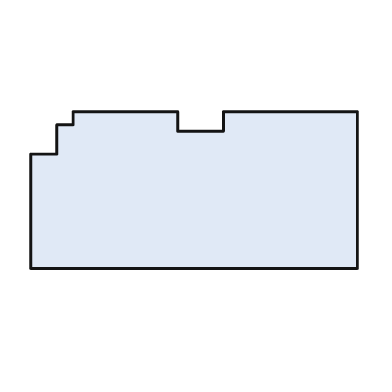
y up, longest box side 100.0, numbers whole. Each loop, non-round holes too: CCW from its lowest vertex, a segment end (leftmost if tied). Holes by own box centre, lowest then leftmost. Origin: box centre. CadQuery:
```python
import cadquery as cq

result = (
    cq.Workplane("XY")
    .moveTo(-50.0, -24.0)
    .lineTo(50.0, -24.0)
    .lineTo(50.0, 24.0)
    .lineTo(9.0, 24.0)
    .lineTo(9.0, 18.0)
    .lineTo(-5.0, 18.0)
    .lineTo(-5.0, 24.0)
    .lineTo(-37.0, 24.0)
    .lineTo(-37.0, 20.0)
    .lineTo(-42.0, 20.0)
    .lineTo(-42.0, 11.0)
    .lineTo(-50.0, 11.0)
    .close()
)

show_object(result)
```